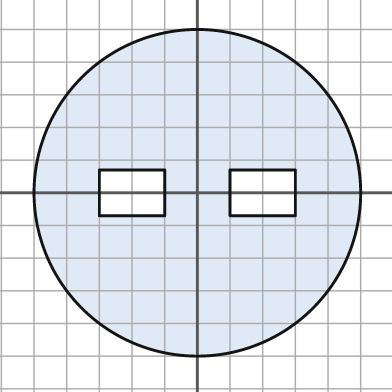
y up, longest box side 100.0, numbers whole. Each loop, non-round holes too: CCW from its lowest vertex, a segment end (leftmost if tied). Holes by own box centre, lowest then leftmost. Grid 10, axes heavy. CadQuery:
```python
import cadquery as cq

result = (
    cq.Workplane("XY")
    .moveTo(0.0, 0.0)
    .circle(50.0)
    .moveTo(-30.0, -7.0)
    .lineTo(-10.0, -7.0)
    .lineTo(-10.0, 7.0)
    .lineTo(-30.0, 7.0)
    .close()
    .moveTo(10.0, -7.0)
    .lineTo(30.0, -7.0)
    .lineTo(30.0, 7.0)
    .lineTo(10.0, 7.0)
    .close()
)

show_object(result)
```